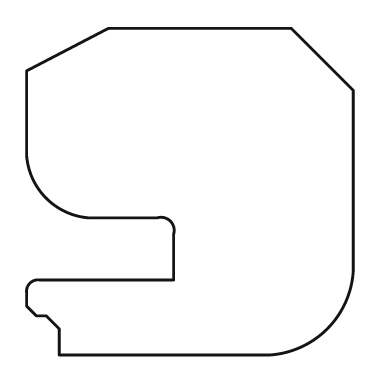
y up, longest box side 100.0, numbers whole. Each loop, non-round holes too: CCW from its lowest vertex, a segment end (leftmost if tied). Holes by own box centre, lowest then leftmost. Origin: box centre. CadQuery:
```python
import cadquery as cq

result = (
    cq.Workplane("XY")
    .moveTo(-40.0, -50.0)
    .lineTo(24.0, -50.0)
    .threePointArc((42.0, -42.0), (50.0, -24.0))
    .lineTo(50.0, 31.0)
    .lineTo(31.0, 50.0)
    .lineTo(-25.0, 50.0)
    .lineTo(-50.0, 37.0)
    .lineTo(-50.0, 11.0)
    .threePointArc((-44.0, -2.0), (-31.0, -8.0))
    .lineTo(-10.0, -8.0)
    .threePointArc((-6.0, -9.0), (-5.0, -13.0))
    .lineTo(-5.0, -27.0)
    .lineTo(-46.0, -27.0)
    .threePointArc((-49.0, -28.0), (-50.0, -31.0))
    .lineTo(-50.0, -35.0)
    .lineTo(-47.0, -38.0)
    .lineTo(-44.0, -38.0)
    .lineTo(-40.0, -42.0)
    .close()
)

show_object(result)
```